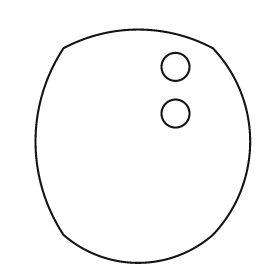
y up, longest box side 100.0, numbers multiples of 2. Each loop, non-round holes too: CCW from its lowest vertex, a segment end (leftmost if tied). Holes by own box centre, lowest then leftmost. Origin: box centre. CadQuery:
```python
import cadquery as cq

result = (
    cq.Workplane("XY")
    .moveTo(-34.0, -38.0)
    .threePointArc((-2.0, -50.0), (30.0, -38.0))
    .threePointArc((46.0, 2.0), (30.0, 42.0))
    .threePointArc((-2.0, 50.0), (-34.0, 42.0))
    .threePointArc((-46.0, 2.0), (-34.0, -38.0))
    .close()
    .moveTo(14.0, 14.0)
    .circle(6.0)
    .moveTo(14.0, 34.0)
    .circle(6.0)
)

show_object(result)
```